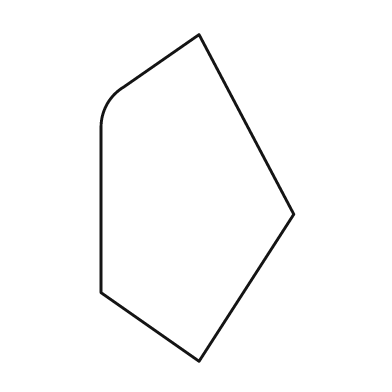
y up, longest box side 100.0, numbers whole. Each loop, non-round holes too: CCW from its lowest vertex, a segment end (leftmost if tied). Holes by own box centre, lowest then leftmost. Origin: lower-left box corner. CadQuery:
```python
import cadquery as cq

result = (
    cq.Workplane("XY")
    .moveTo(30.0, 0.0)
    .lineTo(59.0, 45.0)
    .lineTo(30.0, 100.0)
    .lineTo(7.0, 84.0)
    .threePointArc((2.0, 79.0), (0.0, 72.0))
    .lineTo(0.0, 21.0)
    .close()
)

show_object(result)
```